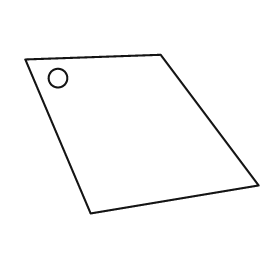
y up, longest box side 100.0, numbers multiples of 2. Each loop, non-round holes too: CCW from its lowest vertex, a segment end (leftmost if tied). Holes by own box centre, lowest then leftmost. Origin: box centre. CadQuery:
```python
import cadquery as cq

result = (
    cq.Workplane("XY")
    .moveTo(-22.0, -34.0)
    .lineTo(50.0, -22.0)
    .lineTo(8.0, 34.0)
    .lineTo(-50.0, 32.0)
    .close()
    .moveTo(-36.0, 24.0)
    .circle(4.0)
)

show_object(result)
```